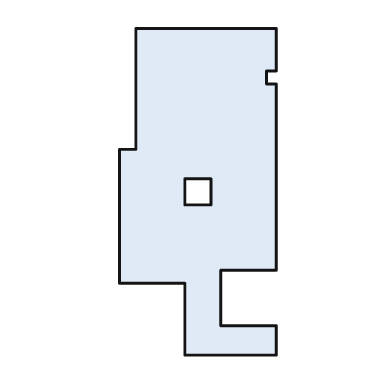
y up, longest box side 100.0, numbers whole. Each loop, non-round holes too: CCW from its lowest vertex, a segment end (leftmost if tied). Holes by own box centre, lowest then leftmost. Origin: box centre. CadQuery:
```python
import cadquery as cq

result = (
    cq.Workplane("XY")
    .moveTo(-4.0, -50.0)
    .lineTo(24.0, -50.0)
    .lineTo(24.0, -41.0)
    .lineTo(7.0, -41.0)
    .lineTo(7.0, -24.0)
    .lineTo(24.0, -24.0)
    .lineTo(24.0, 33.0)
    .lineTo(21.0, 33.0)
    .lineTo(21.0, 37.0)
    .lineTo(24.0, 37.0)
    .lineTo(24.0, 50.0)
    .lineTo(-19.0, 50.0)
    .lineTo(-19.0, 13.0)
    .lineTo(-24.0, 13.0)
    .lineTo(-24.0, -28.0)
    .lineTo(-4.0, -28.0)
    .close()
    .moveTo(-4.0, -4.0)
    .lineTo(4.0, -4.0)
    .lineTo(4.0, 4.0)
    .lineTo(-4.0, 4.0)
    .close()
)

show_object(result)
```